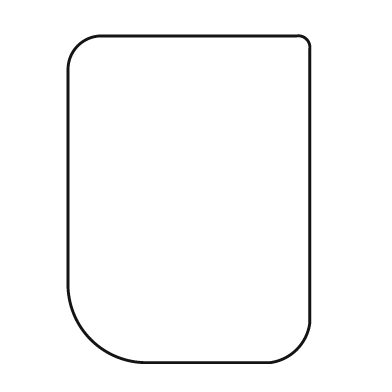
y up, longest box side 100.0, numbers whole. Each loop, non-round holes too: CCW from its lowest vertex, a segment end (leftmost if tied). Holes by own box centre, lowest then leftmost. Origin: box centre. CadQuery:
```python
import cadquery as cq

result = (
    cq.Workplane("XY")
    .moveTo(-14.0, -50.0)
    .lineTo(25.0, -50.0)
    .threePointArc((33.0, -46.0), (37.0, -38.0))
    .lineTo(37.0, 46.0)
    .threePointArc((36.0, 49.0), (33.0, 50.0))
    .lineTo(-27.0, 50.0)
    .threePointArc((-34.0, 47.0), (-37.0, 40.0))
    .lineTo(-37.0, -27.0)
    .threePointArc((-30.0, -43.0), (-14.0, -50.0))
    .close()
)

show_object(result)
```